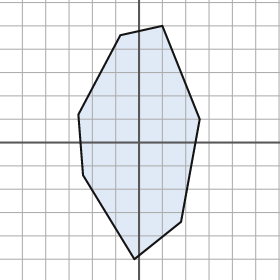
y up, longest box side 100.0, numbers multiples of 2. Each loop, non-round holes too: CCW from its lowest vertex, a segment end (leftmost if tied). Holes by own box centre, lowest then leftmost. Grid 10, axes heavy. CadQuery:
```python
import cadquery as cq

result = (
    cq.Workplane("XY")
    .moveTo(-2.0, -50.0)
    .lineTo(18.0, -34.0)
    .lineTo(26.0, 10.0)
    .lineTo(10.0, 50.0)
    .lineTo(-8.0, 46.0)
    .lineTo(-26.0, 12.0)
    .lineTo(-24.0, -14.0)
    .close()
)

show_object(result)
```